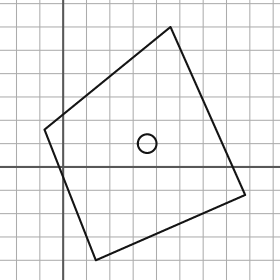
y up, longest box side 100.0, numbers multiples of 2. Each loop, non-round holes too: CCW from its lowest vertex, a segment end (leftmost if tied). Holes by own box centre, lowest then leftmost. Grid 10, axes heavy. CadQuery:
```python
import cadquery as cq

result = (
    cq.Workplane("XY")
    .moveTo(14.0, -40.0)
    .lineTo(78.0, -12.0)
    .lineTo(46.0, 60.0)
    .lineTo(-8.0, 16.0)
    .close()
    .moveTo(36.0, 10.0)
    .circle(4.0)
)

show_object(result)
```